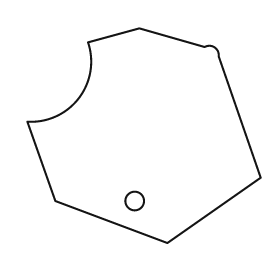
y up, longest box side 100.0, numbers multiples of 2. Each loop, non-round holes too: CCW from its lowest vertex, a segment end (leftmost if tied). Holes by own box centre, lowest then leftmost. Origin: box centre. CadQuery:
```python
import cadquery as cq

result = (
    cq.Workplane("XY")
    .moveTo(10.0, -46.0)
    .lineTo(50.0, -18.0)
    .lineTo(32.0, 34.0)
    .threePointArc((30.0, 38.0), (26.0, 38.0))
    .lineTo(-2.0, 46.0)
    .lineTo(-24.0, 40.0)
    .threePointArc((-28.0, 16.0), (-50.0, 6.0))
    .lineTo(-38.0, -28.0)
    .close()
    .moveTo(-4.0, -28.0)
    .circle(4.0)
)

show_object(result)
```